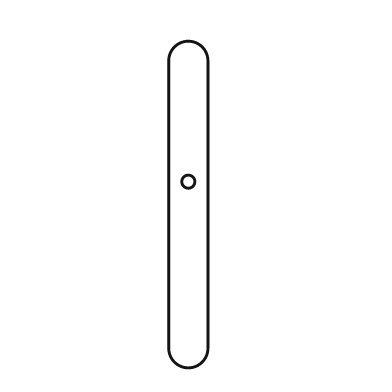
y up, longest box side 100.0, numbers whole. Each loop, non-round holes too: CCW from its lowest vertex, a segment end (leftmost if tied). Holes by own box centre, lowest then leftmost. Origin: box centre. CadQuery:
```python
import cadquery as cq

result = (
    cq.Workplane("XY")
    .moveTo(-6.0, -44.0)
    .threePointArc((0.0, -50.0), (6.0, -44.0))
    .lineTo(6.0, 44.0)
    .threePointArc((0.0, 50.0), (-6.0, 44.0))
    .close()
    .moveTo(0.0, 7.0)
    .circle(2.0)
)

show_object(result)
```